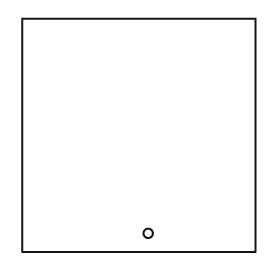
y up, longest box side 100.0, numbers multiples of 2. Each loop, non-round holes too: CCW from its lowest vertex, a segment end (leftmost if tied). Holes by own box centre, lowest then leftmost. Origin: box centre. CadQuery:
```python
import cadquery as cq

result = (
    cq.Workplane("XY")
    .moveTo(-50.0, -50.0)
    .lineTo(50.0, -50.0)
    .lineTo(50.0, 50.0)
    .lineTo(-50.0, 50.0)
    .close()
    .moveTo(4.0, -42.0)
    .circle(2.0)
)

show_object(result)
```